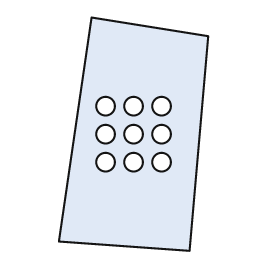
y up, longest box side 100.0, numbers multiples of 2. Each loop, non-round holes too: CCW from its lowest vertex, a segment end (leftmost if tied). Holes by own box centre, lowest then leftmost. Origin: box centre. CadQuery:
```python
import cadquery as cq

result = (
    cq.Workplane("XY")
    .moveTo(24.0, -50.0)
    .lineTo(32.0, 42.0)
    .lineTo(-18.0, 50.0)
    .lineTo(-32.0, -46.0)
    .close()
    .moveTo(-12.0, -12.0)
    .circle(4.0)
    .moveTo(0.0, -12.0)
    .circle(4.0)
    .moveTo(12.0, -12.0)
    .circle(4.0)
    .moveTo(-12.0, 0.0)
    .circle(4.0)
    .moveTo(0.0, 0.0)
    .circle(4.0)
    .moveTo(12.0, 0.0)
    .circle(4.0)
    .moveTo(-12.0, 12.0)
    .circle(4.0)
    .moveTo(0.0, 12.0)
    .circle(4.0)
    .moveTo(12.0, 12.0)
    .circle(4.0)
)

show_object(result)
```